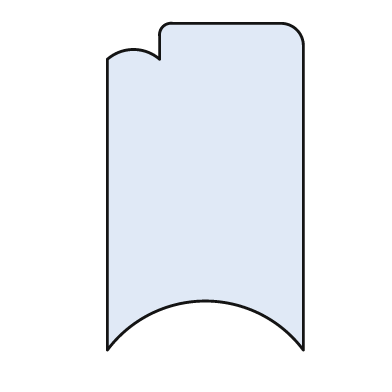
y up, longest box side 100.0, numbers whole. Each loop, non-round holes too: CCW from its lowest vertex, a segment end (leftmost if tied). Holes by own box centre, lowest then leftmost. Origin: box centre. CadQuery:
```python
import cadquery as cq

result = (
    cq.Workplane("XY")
    .moveTo(-30.0, -50.0)
    .threePointArc((0.0, -35.0), (30.0, -50.0))
    .lineTo(30.0, 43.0)
    .threePointArc((28.0, 48.0), (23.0, 50.0))
    .lineTo(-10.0, 50.0)
    .threePointArc((-13.0, 49.0), (-14.0, 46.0))
    .lineTo(-14.0, 39.0)
    .threePointArc((-22.0, 42.0), (-30.0, 39.0))
    .close()
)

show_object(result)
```